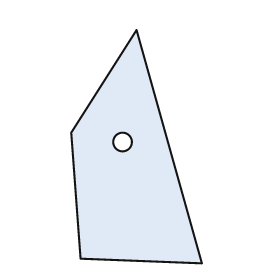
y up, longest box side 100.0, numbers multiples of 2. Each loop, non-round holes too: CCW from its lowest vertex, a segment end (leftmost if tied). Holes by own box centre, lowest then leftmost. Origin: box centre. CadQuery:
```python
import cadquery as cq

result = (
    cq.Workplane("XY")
    .moveTo(28.0, -50.0)
    .lineTo(0.0, 50.0)
    .lineTo(-28.0, 6.0)
    .lineTo(-24.0, -48.0)
    .close()
    .moveTo(-6.0, 2.0)
    .circle(4.0)
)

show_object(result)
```